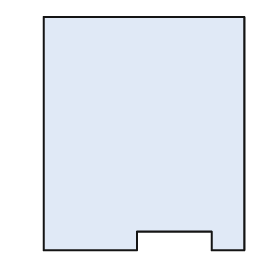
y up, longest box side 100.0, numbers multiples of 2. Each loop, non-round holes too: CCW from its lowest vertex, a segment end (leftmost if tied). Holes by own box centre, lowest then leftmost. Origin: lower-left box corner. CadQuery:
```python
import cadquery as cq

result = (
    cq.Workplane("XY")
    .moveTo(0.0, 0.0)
    .lineTo(40.0, 0.0)
    .lineTo(40.0, 8.0)
    .lineTo(72.0, 8.0)
    .lineTo(72.0, 0.0)
    .lineTo(86.0, 0.0)
    .lineTo(86.0, 100.0)
    .lineTo(0.0, 100.0)
    .close()
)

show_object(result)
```